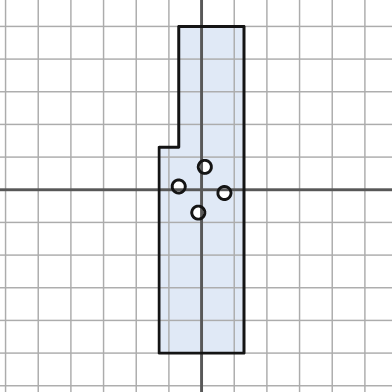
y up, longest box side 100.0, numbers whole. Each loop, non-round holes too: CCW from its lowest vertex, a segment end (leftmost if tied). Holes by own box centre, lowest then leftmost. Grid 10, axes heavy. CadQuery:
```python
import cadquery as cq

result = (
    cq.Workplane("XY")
    .moveTo(-13.0, -50.0)
    .lineTo(13.0, -50.0)
    .lineTo(13.0, 50.0)
    .lineTo(-7.0, 50.0)
    .lineTo(-7.0, 13.0)
    .lineTo(-13.0, 13.0)
    .close()
    .moveTo(-1.0, -7.0)
    .circle(2.0)
    .moveTo(7.0, -1.0)
    .circle(2.0)
    .moveTo(-7.0, 1.0)
    .circle(2.0)
    .moveTo(1.0, 7.0)
    .circle(2.0)
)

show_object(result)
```